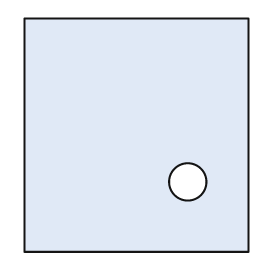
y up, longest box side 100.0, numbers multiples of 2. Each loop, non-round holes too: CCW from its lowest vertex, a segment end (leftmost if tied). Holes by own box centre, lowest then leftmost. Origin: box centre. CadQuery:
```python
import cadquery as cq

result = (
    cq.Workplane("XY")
    .moveTo(-48.0, -50.0)
    .lineTo(48.0, -50.0)
    .lineTo(48.0, 50.0)
    .lineTo(-48.0, 50.0)
    .close()
    .moveTo(22.0, -20.0)
    .circle(8.0)
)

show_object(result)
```